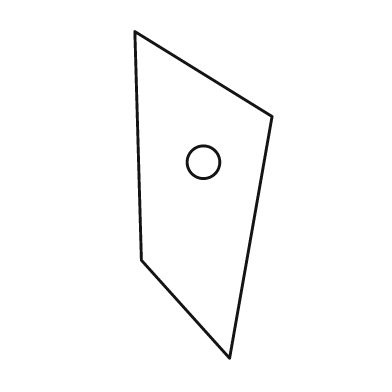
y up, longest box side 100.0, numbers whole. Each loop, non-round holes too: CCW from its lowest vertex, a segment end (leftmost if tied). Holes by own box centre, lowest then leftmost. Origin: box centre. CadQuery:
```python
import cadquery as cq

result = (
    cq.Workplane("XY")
    .moveTo(8.0, -50.0)
    .lineTo(21.0, 24.0)
    .lineTo(-21.0, 50.0)
    .lineTo(-19.0, -20.0)
    .close()
    .moveTo(0.0, 10.0)
    .circle(5.0)
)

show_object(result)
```